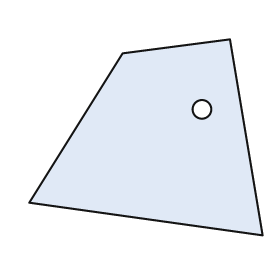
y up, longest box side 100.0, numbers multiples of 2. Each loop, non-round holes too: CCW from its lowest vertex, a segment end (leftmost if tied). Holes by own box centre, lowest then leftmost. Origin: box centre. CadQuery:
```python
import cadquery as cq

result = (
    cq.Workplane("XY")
    .moveTo(50.0, -42.0)
    .lineTo(36.0, 42.0)
    .lineTo(-10.0, 36.0)
    .lineTo(-50.0, -28.0)
    .close()
    .moveTo(24.0, 12.0)
    .circle(4.0)
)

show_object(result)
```